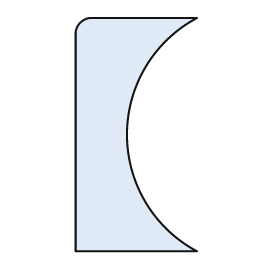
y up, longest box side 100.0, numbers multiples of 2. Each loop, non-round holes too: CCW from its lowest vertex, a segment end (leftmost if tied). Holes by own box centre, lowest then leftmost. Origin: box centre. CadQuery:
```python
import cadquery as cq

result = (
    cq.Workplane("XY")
    .moveTo(-26.0, -50.0)
    .lineTo(26.0, -50.0)
    .threePointArc((-4.0, 0.0), (26.0, 50.0))
    .lineTo(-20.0, 50.0)
    .threePointArc((-24.0, 48.0), (-26.0, 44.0))
    .close()
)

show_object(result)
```